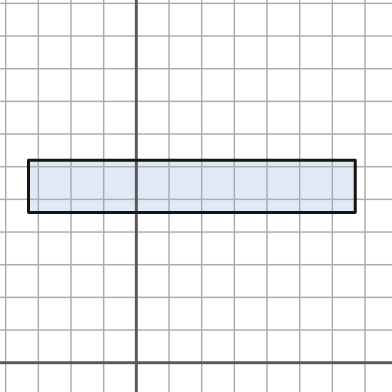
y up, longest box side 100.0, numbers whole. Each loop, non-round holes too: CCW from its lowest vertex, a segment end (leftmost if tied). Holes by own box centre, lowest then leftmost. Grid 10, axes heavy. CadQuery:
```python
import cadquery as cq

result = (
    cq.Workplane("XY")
    .moveTo(-33.0, 46.0)
    .lineTo(67.0, 46.0)
    .lineTo(67.0, 62.0)
    .lineTo(-33.0, 62.0)
    .close()
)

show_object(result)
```